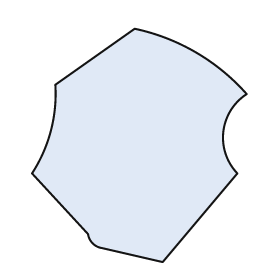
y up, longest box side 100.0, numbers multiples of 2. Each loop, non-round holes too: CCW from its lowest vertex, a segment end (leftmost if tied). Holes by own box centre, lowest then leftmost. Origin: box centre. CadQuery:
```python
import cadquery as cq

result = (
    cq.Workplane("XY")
    .moveTo(10.0, -50.0)
    .lineTo(42.0, -12.0)
    .threePointArc((36.0, 6.0), (46.0, 22.0))
    .threePointArc((24.0, 40.0), (-2.0, 50.0))
    .lineTo(-36.0, 26.0)
    .threePointArc((-38.0, 6.0), (-46.0, -12.0))
    .lineTo(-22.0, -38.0)
    .threePointArc((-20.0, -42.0), (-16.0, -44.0))
    .close()
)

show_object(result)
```